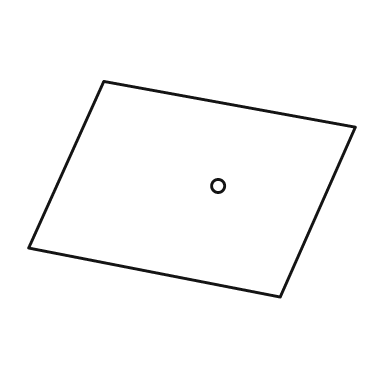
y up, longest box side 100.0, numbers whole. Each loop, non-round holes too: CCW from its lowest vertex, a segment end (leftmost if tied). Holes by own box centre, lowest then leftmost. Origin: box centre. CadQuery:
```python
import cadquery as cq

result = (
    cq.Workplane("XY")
    .moveTo(27.0, -33.0)
    .lineTo(50.0, 19.0)
    .lineTo(-27.0, 33.0)
    .lineTo(-50.0, -18.0)
    .close()
    .moveTo(8.0, 1.0)
    .circle(2.0)
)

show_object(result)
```